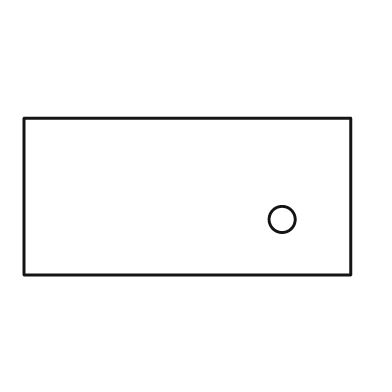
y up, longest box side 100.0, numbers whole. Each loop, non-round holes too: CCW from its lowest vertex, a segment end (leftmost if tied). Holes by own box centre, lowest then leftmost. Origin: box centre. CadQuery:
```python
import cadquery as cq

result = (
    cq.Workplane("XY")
    .moveTo(-50.0, -24.0)
    .lineTo(50.0, -24.0)
    .lineTo(50.0, 24.0)
    .lineTo(-50.0, 24.0)
    .close()
    .moveTo(29.0, -7.0)
    .circle(4.0)
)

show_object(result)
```